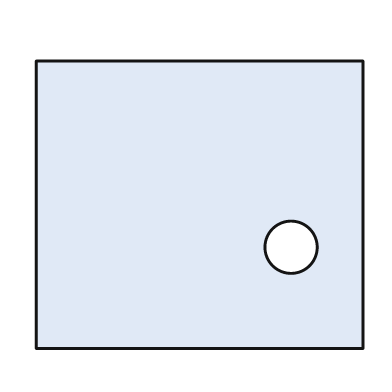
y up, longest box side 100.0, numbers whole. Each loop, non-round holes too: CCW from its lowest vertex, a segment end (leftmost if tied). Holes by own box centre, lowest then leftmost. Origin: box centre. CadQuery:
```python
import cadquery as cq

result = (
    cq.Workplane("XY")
    .moveTo(-50.0, -44.0)
    .lineTo(50.0, -44.0)
    .lineTo(50.0, 44.0)
    .lineTo(-50.0, 44.0)
    .close()
    .moveTo(28.0, -13.0)
    .circle(8.0)
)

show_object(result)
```